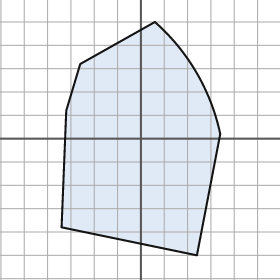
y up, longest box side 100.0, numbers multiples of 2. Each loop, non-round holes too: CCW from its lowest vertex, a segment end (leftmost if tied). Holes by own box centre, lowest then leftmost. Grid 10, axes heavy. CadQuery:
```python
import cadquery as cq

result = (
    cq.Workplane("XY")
    .moveTo(24.0, -50.0)
    .lineTo(34.0, 2.0)
    .threePointArc((24.0, 28.0), (6.0, 50.0))
    .lineTo(-26.0, 32.0)
    .lineTo(-32.0, 12.0)
    .lineTo(-34.0, -38.0)
    .close()
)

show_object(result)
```